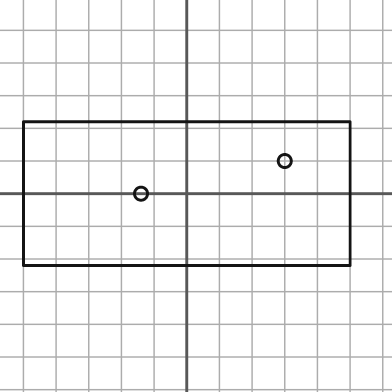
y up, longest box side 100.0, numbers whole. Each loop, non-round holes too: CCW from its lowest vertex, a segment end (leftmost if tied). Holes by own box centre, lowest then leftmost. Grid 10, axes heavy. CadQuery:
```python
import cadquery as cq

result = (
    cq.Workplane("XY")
    .moveTo(-50.0, -22.0)
    .lineTo(50.0, -22.0)
    .lineTo(50.0, 22.0)
    .lineTo(-50.0, 22.0)
    .close()
    .moveTo(-14.0, 0.0)
    .circle(2.0)
    .moveTo(30.0, 10.0)
    .circle(2.0)
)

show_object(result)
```